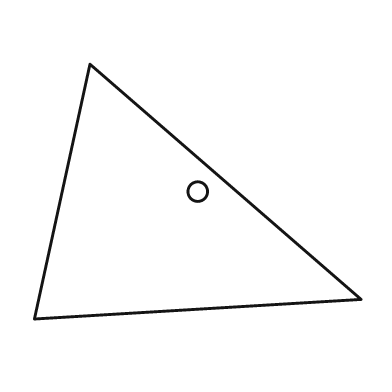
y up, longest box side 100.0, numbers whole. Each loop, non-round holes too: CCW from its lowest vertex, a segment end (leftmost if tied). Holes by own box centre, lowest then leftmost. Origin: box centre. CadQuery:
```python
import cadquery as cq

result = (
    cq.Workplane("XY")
    .moveTo(-50.0, -39.0)
    .lineTo(50.0, -33.0)
    .lineTo(-33.0, 39.0)
    .close()
    .moveTo(0.0, 0.0)
    .circle(3.0)
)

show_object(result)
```